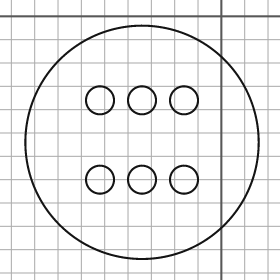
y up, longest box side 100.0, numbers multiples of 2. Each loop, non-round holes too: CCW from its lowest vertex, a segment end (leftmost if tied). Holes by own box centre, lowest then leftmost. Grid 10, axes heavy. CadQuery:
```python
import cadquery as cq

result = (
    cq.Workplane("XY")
    .moveTo(-34.0, -54.0)
    .circle(50.0)
    .moveTo(-52.0, -70.0)
    .circle(6.0)
    .moveTo(-34.0, -70.0)
    .circle(6.0)
    .moveTo(-16.0, -70.0)
    .circle(6.0)
    .moveTo(-52.0, -36.0)
    .circle(6.0)
    .moveTo(-34.0, -36.0)
    .circle(6.0)
    .moveTo(-16.0, -36.0)
    .circle(6.0)
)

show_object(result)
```